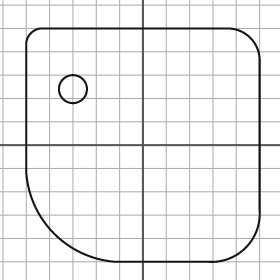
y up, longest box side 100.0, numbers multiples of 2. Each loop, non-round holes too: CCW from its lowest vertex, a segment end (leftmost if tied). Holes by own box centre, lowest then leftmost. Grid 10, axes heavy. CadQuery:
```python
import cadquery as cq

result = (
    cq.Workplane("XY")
    .moveTo(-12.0, -50.0)
    .lineTo(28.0, -50.0)
    .threePointArc((44.0, -44.0), (50.0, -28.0))
    .lineTo(50.0, 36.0)
    .threePointArc((46.0, 46.0), (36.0, 50.0))
    .lineTo(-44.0, 50.0)
    .threePointArc((-48.0, 48.0), (-50.0, 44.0))
    .lineTo(-50.0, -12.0)
    .threePointArc((-38.0, -38.0), (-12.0, -50.0))
    .close()
    .moveTo(-30.0, 24.0)
    .circle(6.0)
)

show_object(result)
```